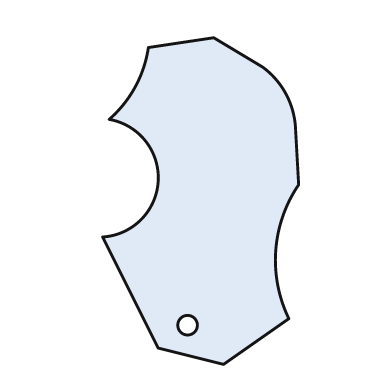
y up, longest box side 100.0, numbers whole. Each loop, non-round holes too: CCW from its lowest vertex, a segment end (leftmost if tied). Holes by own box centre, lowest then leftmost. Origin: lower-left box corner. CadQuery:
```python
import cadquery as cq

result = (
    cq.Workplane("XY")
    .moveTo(37.0, 0.0)
    .lineTo(57.0, 14.0)
    .threePointArc((53.0, 35.0), (60.0, 55.0))
    .lineTo(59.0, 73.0)
    .threePointArc((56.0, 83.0), (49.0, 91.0))
    .lineTo(34.0, 100.0)
    .lineTo(14.0, 97.0)
    .threePointArc((10.0, 85.0), (2.0, 75.0))
    .threePointArc((17.0, 56.0), (0.0, 39.0))
    .lineTo(17.0, 5.0)
    .close()
    .moveTo(26.0, 12.0)
    .circle(3.0)
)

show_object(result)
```